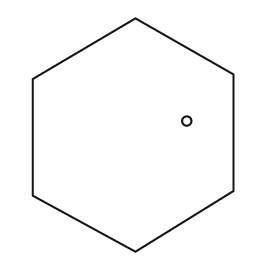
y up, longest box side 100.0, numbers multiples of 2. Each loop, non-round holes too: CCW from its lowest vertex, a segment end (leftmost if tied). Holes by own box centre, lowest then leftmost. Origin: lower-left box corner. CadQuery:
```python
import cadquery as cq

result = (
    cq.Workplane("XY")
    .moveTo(44.0, 0.0)
    .lineTo(86.0, 26.0)
    .lineTo(86.0, 76.0)
    .lineTo(44.0, 100.0)
    .lineTo(0.0, 74.0)
    .lineTo(0.0, 24.0)
    .close()
    .moveTo(66.0, 56.0)
    .circle(2.0)
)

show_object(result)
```